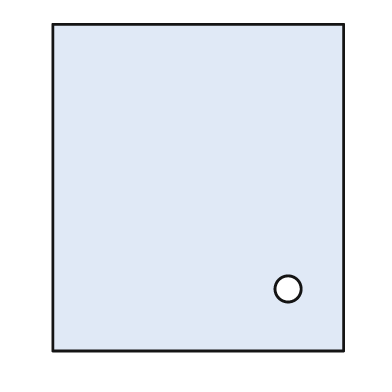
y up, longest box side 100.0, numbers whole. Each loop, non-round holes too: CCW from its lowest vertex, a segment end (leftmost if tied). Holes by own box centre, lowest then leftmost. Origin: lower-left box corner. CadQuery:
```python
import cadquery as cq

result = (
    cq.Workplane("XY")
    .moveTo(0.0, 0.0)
    .lineTo(89.0, 0.0)
    .lineTo(89.0, 100.0)
    .lineTo(0.0, 100.0)
    .close()
    .moveTo(72.0, 19.0)
    .circle(4.0)
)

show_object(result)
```